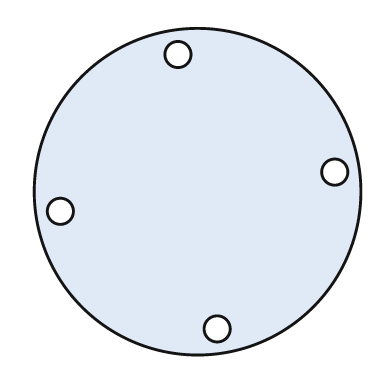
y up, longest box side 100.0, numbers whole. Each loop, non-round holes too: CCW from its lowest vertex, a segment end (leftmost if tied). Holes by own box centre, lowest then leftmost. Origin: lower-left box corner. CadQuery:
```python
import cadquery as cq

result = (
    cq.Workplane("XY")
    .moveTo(50.0, 50.0)
    .circle(50.0)
    .moveTo(56.0, 8.0)
    .circle(4.0)
    .moveTo(8.0, 44.0)
    .circle(4.0)
    .moveTo(92.0, 56.0)
    .circle(4.0)
    .moveTo(44.0, 92.0)
    .circle(4.0)
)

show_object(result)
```